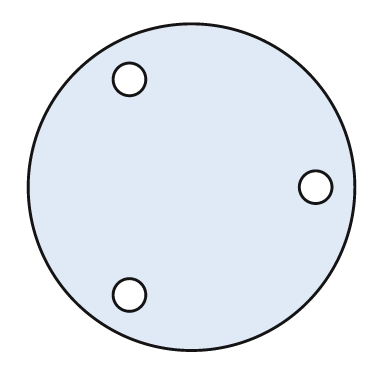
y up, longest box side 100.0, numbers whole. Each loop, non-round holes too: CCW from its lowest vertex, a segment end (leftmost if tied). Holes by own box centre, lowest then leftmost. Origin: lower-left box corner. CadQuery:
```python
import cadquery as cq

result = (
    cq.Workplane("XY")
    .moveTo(50.0, 50.0)
    .circle(50.0)
    .moveTo(31.0, 17.0)
    .circle(5.0)
    .moveTo(88.0, 50.0)
    .circle(5.0)
    .moveTo(31.0, 83.0)
    .circle(5.0)
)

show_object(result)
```